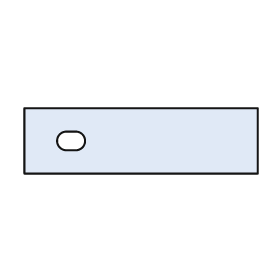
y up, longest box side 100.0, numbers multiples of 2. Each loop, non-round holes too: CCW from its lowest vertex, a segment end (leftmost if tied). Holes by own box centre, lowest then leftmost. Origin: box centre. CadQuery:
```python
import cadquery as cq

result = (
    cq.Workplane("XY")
    .moveTo(-50.0, -14.0)
    .lineTo(50.0, -14.0)
    .lineTo(50.0, 14.0)
    .lineTo(-50.0, 14.0)
    .close()
    .moveTo(-32.0, -4.0)
    .lineTo(-28.0, -4.0)
    .threePointArc((-24.0, 0.0), (-28.0, 4.0))
    .lineTo(-32.0, 4.0)
    .threePointArc((-36.0, 0.0), (-32.0, -4.0))
    .close()
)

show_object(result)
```